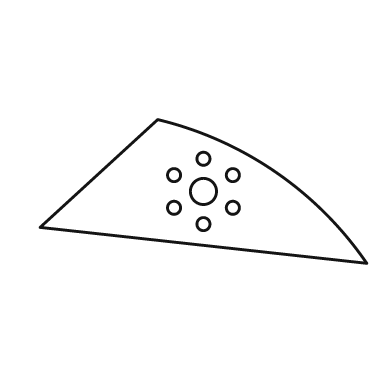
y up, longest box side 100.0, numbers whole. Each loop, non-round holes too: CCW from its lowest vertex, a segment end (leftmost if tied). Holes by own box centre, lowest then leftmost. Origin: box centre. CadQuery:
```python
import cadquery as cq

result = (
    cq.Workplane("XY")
    .moveTo(50.0, -22.0)
    .threePointArc((22.0, 6.0), (-14.0, 22.0))
    .lineTo(-50.0, -11.0)
    .close()
    .moveTo(0.0, -10.0)
    .circle(2.0)
    .moveTo(-9.0, -5.0)
    .circle(2.0)
    .moveTo(9.0, -5.0)
    .circle(2.0)
    .moveTo(0.0, 0.0)
    .circle(4.0)
    .moveTo(-9.0, 5.0)
    .circle(2.0)
    .moveTo(9.0, 5.0)
    .circle(2.0)
    .moveTo(0.0, 10.0)
    .circle(2.0)
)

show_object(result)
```